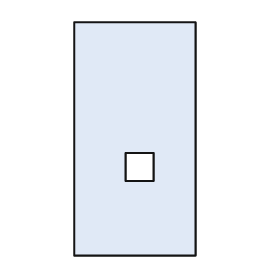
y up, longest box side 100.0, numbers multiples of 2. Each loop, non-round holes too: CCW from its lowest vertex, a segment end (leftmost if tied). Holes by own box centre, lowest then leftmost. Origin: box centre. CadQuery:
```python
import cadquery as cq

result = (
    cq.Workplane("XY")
    .moveTo(-26.0, -50.0)
    .lineTo(26.0, -50.0)
    .lineTo(26.0, 50.0)
    .lineTo(-26.0, 50.0)
    .close()
    .moveTo(-4.0, -18.0)
    .lineTo(8.0, -18.0)
    .lineTo(8.0, -6.0)
    .lineTo(-4.0, -6.0)
    .close()
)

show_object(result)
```